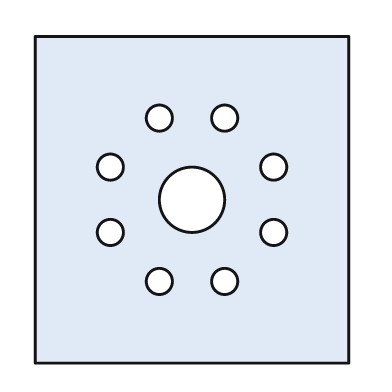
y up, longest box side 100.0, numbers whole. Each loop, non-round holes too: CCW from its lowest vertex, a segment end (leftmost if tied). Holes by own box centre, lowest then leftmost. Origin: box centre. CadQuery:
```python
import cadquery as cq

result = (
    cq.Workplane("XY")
    .moveTo(-48.0, -50.0)
    .lineTo(48.0, -50.0)
    .lineTo(48.0, 50.0)
    .lineTo(-48.0, 50.0)
    .close()
    .moveTo(-10.0, -25.0)
    .circle(4.0)
    .moveTo(10.0, -25.0)
    .circle(4.0)
    .moveTo(-25.0, -10.0)
    .circle(4.0)
    .moveTo(25.0, -10.0)
    .circle(4.0)
    .moveTo(0.0, 0.0)
    .circle(10.0)
    .moveTo(-25.0, 10.0)
    .circle(4.0)
    .moveTo(25.0, 10.0)
    .circle(4.0)
    .moveTo(-10.0, 25.0)
    .circle(4.0)
    .moveTo(10.0, 25.0)
    .circle(4.0)
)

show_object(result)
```